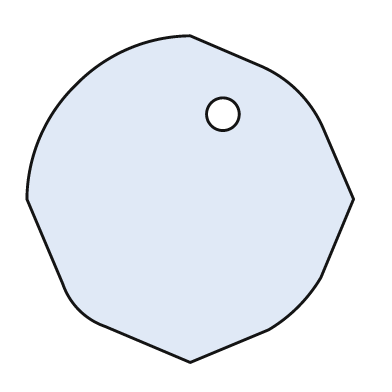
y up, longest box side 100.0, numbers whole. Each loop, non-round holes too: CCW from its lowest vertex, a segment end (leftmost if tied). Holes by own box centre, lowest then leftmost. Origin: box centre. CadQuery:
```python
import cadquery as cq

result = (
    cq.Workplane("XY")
    .moveTo(0.0, -50.0)
    .lineTo(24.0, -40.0)
    .threePointArc((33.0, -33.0), (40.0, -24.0))
    .lineTo(50.0, 0.0)
    .lineTo(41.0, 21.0)
    .threePointArc((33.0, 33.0), (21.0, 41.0))
    .lineTo(0.0, 50.0)
    .threePointArc((-19.0, 46.0), (-35.0, 35.0))
    .threePointArc((-46.0, 19.0), (-50.0, 0.0))
    .lineTo(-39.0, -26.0)
    .threePointArc((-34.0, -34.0), (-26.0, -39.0))
    .close()
    .moveTo(10.0, 26.0)
    .circle(5.0)
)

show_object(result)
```